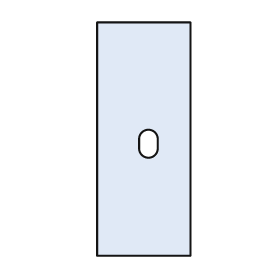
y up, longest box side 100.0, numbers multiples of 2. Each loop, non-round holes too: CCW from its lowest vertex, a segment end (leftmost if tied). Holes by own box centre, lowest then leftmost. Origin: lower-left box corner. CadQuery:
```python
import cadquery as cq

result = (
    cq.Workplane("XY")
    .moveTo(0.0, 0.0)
    .lineTo(40.0, 0.0)
    .lineTo(40.0, 100.0)
    .lineTo(0.0, 100.0)
    .close()
    .moveTo(18.0, 46.0)
    .threePointArc((22.0, 42.0), (26.0, 46.0))
    .lineTo(26.0, 50.0)
    .threePointArc((22.0, 54.0), (18.0, 50.0))
    .close()
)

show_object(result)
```